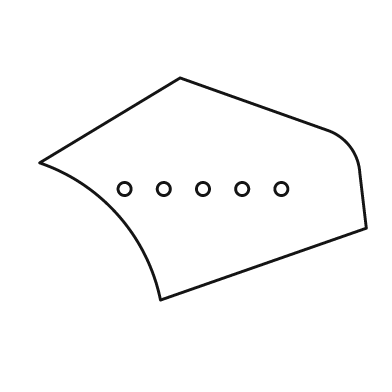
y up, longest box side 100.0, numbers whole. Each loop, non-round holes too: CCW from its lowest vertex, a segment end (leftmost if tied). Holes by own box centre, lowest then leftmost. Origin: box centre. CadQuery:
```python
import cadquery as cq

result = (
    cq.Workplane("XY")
    .moveTo(-13.0, -34.0)
    .lineTo(50.0, -12.0)
    .lineTo(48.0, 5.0)
    .threePointArc((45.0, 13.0), (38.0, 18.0))
    .lineTo(-7.0, 34.0)
    .lineTo(-50.0, 8.0)
    .threePointArc((-26.0, -8.0), (-13.0, -34.0))
    .close()
    .moveTo(-24.0, 0.0)
    .circle(2.0)
    .moveTo(-12.0, 0.0)
    .circle(2.0)
    .moveTo(0.0, 0.0)
    .circle(2.0)
    .moveTo(12.0, 0.0)
    .circle(2.0)
    .moveTo(24.0, 0.0)
    .circle(2.0)
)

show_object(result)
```